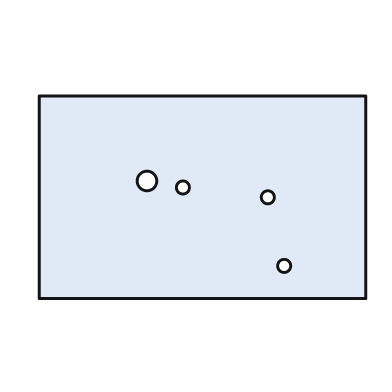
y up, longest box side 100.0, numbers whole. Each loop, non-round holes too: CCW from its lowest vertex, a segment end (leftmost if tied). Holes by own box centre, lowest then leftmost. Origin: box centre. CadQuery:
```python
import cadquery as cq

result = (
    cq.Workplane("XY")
    .moveTo(-50.0, -31.0)
    .lineTo(50.0, -31.0)
    .lineTo(50.0, 31.0)
    .lineTo(-50.0, 31.0)
    .close()
    .moveTo(25.0, -21.0)
    .circle(2.0)
    .moveTo(20.0, 0.0)
    .circle(2.0)
    .moveTo(-6.0, 3.0)
    .circle(2.0)
    .moveTo(-17.0, 5.0)
    .circle(3.0)
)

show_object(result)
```